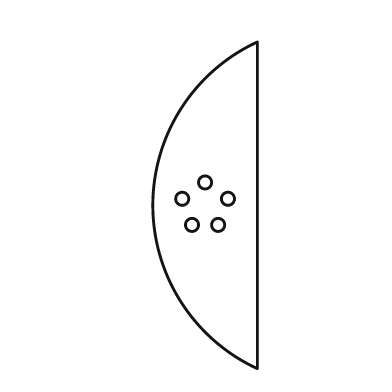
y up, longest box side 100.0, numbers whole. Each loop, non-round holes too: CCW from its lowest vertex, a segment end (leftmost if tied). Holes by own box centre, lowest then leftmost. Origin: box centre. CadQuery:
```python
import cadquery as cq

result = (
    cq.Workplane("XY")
    .moveTo(16.0, -50.0)
    .lineTo(16.0, 50.0)
    .threePointArc((-16.0, 0.0), (16.0, -50.0))
    .close()
    .moveTo(-4.0, -6.0)
    .circle(2.0)
    .moveTo(4.0, -6.0)
    .circle(2.0)
    .moveTo(-7.0, 2.0)
    .circle(2.0)
    .moveTo(7.0, 2.0)
    .circle(2.0)
    .moveTo(0.0, 7.0)
    .circle(2.0)
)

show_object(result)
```